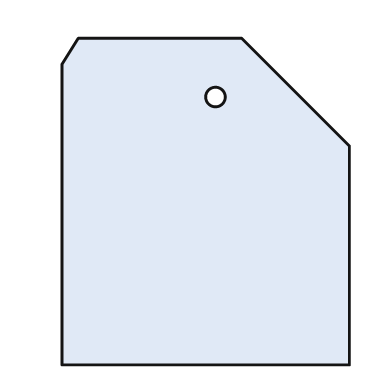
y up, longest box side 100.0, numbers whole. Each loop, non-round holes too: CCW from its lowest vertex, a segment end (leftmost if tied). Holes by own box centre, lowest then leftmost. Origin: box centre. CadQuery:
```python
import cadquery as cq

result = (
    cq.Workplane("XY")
    .moveTo(-44.0, -50.0)
    .lineTo(44.0, -50.0)
    .lineTo(44.0, 17.0)
    .lineTo(11.0, 50.0)
    .lineTo(-39.0, 50.0)
    .lineTo(-44.0, 42.0)
    .close()
    .moveTo(3.0, 32.0)
    .circle(3.0)
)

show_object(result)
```